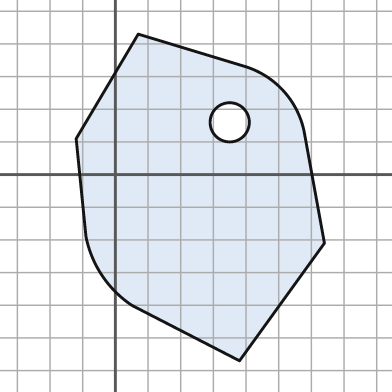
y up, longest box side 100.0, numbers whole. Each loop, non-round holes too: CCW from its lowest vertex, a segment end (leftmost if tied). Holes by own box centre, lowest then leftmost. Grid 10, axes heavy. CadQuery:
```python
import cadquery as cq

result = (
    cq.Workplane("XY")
    .moveTo(38.0, -57.0)
    .lineTo(64.0, -21.0)
    .lineTo(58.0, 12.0)
    .threePointArc((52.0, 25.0), (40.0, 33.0))
    .lineTo(7.0, 43.0)
    .lineTo(-12.0, 11.0)
    .lineTo(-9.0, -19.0)
    .threePointArc((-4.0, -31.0), (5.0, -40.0))
    .close()
    .moveTo(35.0, 16.0)
    .circle(6.0)
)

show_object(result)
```